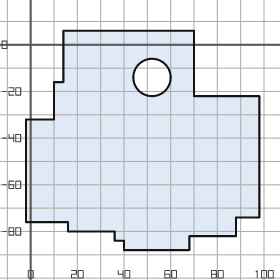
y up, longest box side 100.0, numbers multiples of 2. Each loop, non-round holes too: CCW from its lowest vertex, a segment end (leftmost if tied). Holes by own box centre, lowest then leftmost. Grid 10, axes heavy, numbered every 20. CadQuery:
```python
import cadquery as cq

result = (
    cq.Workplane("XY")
    .moveTo(40.0, -88.0)
    .lineTo(68.0, -88.0)
    .lineTo(68.0, -82.0)
    .lineTo(88.0, -82.0)
    .lineTo(88.0, -74.0)
    .lineTo(98.0, -74.0)
    .lineTo(98.0, -22.0)
    .lineTo(70.0, -22.0)
    .lineTo(70.0, 6.0)
    .lineTo(14.0, 6.0)
    .lineTo(14.0, -16.0)
    .lineTo(10.0, -16.0)
    .lineTo(10.0, -32.0)
    .lineTo(-2.0, -32.0)
    .lineTo(-2.0, -76.0)
    .lineTo(16.0, -76.0)
    .lineTo(16.0, -80.0)
    .lineTo(36.0, -80.0)
    .lineTo(36.0, -84.0)
    .lineTo(40.0, -84.0)
    .close()
    .moveTo(52.0, -14.0)
    .circle(8.0)
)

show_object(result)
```